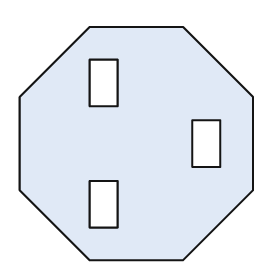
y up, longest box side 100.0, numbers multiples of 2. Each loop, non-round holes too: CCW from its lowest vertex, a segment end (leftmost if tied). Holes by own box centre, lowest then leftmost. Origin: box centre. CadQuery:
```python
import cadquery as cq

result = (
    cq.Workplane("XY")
    .moveTo(-20.0, -50.0)
    .lineTo(20.0, -50.0)
    .lineTo(50.0, -20.0)
    .lineTo(50.0, 20.0)
    .lineTo(20.0, 50.0)
    .lineTo(-20.0, 50.0)
    .lineTo(-50.0, 20.0)
    .lineTo(-50.0, -20.0)
    .close()
    .moveTo(-20.0, -36.0)
    .lineTo(-8.0, -36.0)
    .lineTo(-8.0, -16.0)
    .lineTo(-20.0, -16.0)
    .close()
    .moveTo(24.0, -10.0)
    .lineTo(36.0, -10.0)
    .lineTo(36.0, 10.0)
    .lineTo(24.0, 10.0)
    .close()
    .moveTo(-20.0, 16.0)
    .lineTo(-8.0, 16.0)
    .lineTo(-8.0, 36.0)
    .lineTo(-20.0, 36.0)
    .close()
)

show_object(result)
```